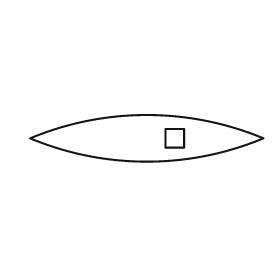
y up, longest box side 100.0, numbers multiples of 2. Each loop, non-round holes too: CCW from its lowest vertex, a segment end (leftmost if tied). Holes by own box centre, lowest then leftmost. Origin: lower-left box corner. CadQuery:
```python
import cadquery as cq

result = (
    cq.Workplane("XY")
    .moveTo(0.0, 10.0)
    .threePointArc((50.0, 0.0), (100.0, 10.0))
    .threePointArc((50.0, 20.0), (0.0, 10.0))
    .close()
    .moveTo(58.0, 6.0)
    .lineTo(66.0, 6.0)
    .lineTo(66.0, 14.0)
    .lineTo(58.0, 14.0)
    .close()
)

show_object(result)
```